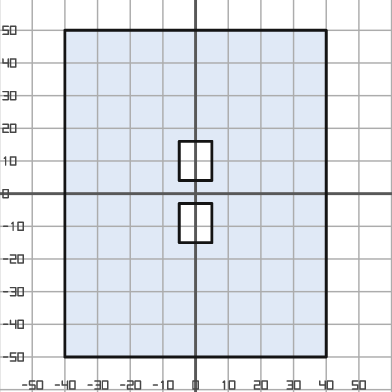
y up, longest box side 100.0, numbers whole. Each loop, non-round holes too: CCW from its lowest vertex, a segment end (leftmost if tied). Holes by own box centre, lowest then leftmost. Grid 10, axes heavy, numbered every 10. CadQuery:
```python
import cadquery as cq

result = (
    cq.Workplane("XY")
    .moveTo(-40.0, -50.0)
    .lineTo(40.0, -50.0)
    .lineTo(40.0, 50.0)
    .lineTo(-40.0, 50.0)
    .close()
    .moveTo(-5.0, -15.0)
    .lineTo(5.0, -15.0)
    .lineTo(5.0, -3.0)
    .lineTo(-5.0, -3.0)
    .close()
    .moveTo(-5.0, 4.0)
    .lineTo(5.0, 4.0)
    .lineTo(5.0, 16.0)
    .lineTo(-5.0, 16.0)
    .close()
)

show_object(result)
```